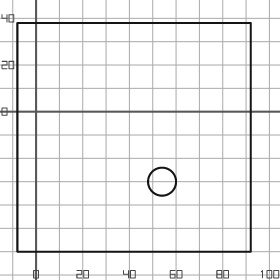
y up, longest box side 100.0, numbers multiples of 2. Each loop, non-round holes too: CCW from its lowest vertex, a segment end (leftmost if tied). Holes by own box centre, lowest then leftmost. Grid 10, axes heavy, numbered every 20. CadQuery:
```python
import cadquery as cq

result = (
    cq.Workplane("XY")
    .moveTo(-8.0, -60.0)
    .lineTo(92.0, -60.0)
    .lineTo(92.0, 38.0)
    .lineTo(-8.0, 38.0)
    .close()
    .moveTo(54.0, -30.0)
    .circle(6.0)
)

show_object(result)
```